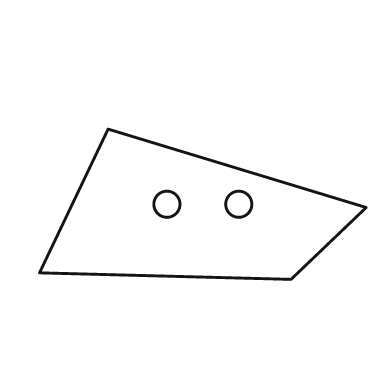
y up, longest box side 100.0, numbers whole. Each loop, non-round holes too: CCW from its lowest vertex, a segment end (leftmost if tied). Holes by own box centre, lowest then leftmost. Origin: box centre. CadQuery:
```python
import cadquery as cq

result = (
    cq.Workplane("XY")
    .moveTo(27.0, -23.0)
    .lineTo(50.0, -1.0)
    .lineTo(-29.0, 23.0)
    .lineTo(-50.0, -21.0)
    .close()
    .moveTo(-11.0, 0.0)
    .circle(4.0)
    .moveTo(11.0, 0.0)
    .circle(4.0)
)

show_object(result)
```